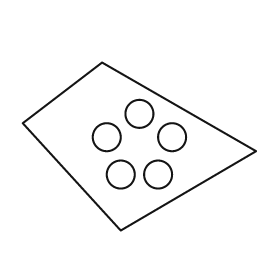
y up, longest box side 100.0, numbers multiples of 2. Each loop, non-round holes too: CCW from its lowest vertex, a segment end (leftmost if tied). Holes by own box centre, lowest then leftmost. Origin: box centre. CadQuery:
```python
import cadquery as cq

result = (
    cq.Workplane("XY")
    .moveTo(-8.0, -36.0)
    .lineTo(50.0, -2.0)
    .lineTo(-16.0, 36.0)
    .lineTo(-50.0, 10.0)
    .close()
    .moveTo(-8.0, -12.0)
    .circle(6.0)
    .moveTo(8.0, -12.0)
    .circle(6.0)
    .moveTo(-14.0, 4.0)
    .circle(6.0)
    .moveTo(14.0, 4.0)
    .circle(6.0)
    .moveTo(0.0, 14.0)
    .circle(6.0)
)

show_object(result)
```